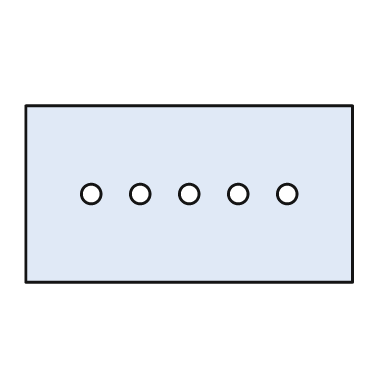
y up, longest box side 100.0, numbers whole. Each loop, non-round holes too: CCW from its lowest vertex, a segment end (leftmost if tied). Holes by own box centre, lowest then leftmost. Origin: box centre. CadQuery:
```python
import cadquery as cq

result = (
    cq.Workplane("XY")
    .moveTo(-50.0, -27.0)
    .lineTo(50.0, -27.0)
    .lineTo(50.0, 27.0)
    .lineTo(-50.0, 27.0)
    .close()
    .moveTo(-30.0, 0.0)
    .circle(3.0)
    .moveTo(-15.0, 0.0)
    .circle(3.0)
    .moveTo(0.0, 0.0)
    .circle(3.0)
    .moveTo(15.0, 0.0)
    .circle(3.0)
    .moveTo(30.0, 0.0)
    .circle(3.0)
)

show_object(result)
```